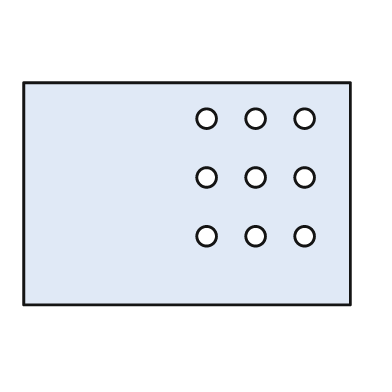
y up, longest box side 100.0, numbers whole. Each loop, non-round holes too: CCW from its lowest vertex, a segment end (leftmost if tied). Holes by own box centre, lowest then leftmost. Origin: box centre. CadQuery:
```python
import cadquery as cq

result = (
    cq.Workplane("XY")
    .moveTo(-50.0, -34.0)
    .lineTo(50.0, -34.0)
    .lineTo(50.0, 34.0)
    .lineTo(-50.0, 34.0)
    .close()
    .moveTo(6.0, -13.0)
    .circle(3.0)
    .moveTo(21.0, -13.0)
    .circle(3.0)
    .moveTo(36.0, -13.0)
    .circle(3.0)
    .moveTo(6.0, 5.0)
    .circle(3.0)
    .moveTo(21.0, 5.0)
    .circle(3.0)
    .moveTo(36.0, 5.0)
    .circle(3.0)
    .moveTo(6.0, 23.0)
    .circle(3.0)
    .moveTo(21.0, 23.0)
    .circle(3.0)
    .moveTo(36.0, 23.0)
    .circle(3.0)
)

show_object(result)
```